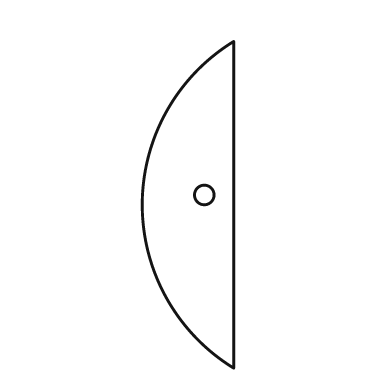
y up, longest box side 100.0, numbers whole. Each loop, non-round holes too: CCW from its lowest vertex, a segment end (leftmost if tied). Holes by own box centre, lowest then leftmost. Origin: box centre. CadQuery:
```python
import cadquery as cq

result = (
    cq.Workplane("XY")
    .moveTo(14.0, -50.0)
    .lineTo(14.0, 50.0)
    .threePointArc((-14.0, 0.0), (14.0, -50.0))
    .close()
    .moveTo(5.0, 3.0)
    .circle(3.0)
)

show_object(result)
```